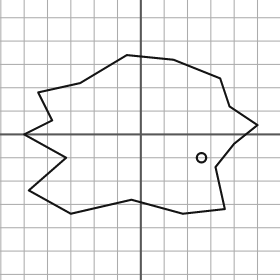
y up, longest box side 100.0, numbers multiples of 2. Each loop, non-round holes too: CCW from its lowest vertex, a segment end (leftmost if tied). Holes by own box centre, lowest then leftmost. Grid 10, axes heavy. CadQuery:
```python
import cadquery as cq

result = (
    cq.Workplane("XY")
    .moveTo(-30.0, -34.0)
    .lineTo(-4.0, -28.0)
    .lineTo(18.0, -34.0)
    .lineTo(36.0, -32.0)
    .lineTo(32.0, -14.0)
    .lineTo(40.0, -4.0)
    .lineTo(50.0, 4.0)
    .lineTo(38.0, 12.0)
    .lineTo(34.0, 24.0)
    .lineTo(14.0, 32.0)
    .lineTo(-6.0, 34.0)
    .lineTo(-26.0, 22.0)
    .lineTo(-44.0, 18.0)
    .lineTo(-38.0, 6.0)
    .lineTo(-50.0, 0.0)
    .lineTo(-32.0, -10.0)
    .lineTo(-48.0, -24.0)
    .close()
    .moveTo(26.0, -10.0)
    .circle(2.0)
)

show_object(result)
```